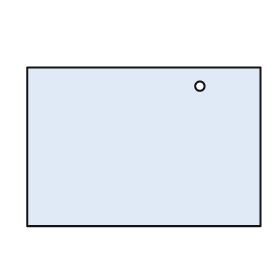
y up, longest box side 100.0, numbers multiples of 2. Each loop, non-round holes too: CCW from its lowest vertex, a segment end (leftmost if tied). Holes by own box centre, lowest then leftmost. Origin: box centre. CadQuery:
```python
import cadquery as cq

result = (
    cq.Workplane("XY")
    .moveTo(-50.0, -34.0)
    .lineTo(50.0, -34.0)
    .lineTo(50.0, 34.0)
    .lineTo(-50.0, 34.0)
    .close()
    .moveTo(24.0, 26.0)
    .circle(2.0)
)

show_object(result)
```